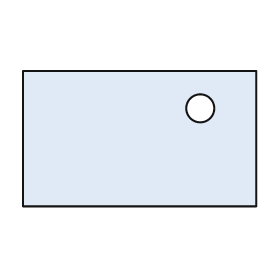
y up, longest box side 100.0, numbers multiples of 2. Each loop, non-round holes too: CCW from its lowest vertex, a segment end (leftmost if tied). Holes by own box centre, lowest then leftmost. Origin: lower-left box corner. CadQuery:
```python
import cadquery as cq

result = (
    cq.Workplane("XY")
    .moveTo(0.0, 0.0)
    .lineTo(100.0, 0.0)
    .lineTo(100.0, 58.0)
    .lineTo(0.0, 58.0)
    .close()
    .moveTo(76.0, 42.0)
    .circle(6.0)
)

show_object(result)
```